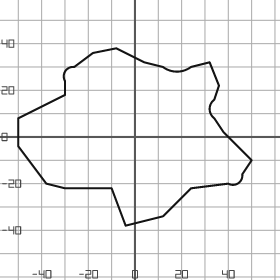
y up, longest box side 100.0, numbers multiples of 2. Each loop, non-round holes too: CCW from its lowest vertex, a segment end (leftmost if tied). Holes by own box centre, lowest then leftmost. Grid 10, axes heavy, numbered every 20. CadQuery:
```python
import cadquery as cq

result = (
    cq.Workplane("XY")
    .moveTo(-4.0, -38.0)
    .lineTo(12.0, -34.0)
    .lineTo(24.0, -22.0)
    .lineTo(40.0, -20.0)
    .threePointArc((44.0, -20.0), (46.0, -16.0))
    .lineTo(50.0, -10.0)
    .lineTo(38.0, 2.0)
    .lineTo(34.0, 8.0)
    .threePointArc((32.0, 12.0), (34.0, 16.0))
    .lineTo(36.0, 22.0)
    .lineTo(32.0, 32.0)
    .lineTo(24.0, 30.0)
    .threePointArc((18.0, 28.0), (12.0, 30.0))
    .lineTo(4.0, 32.0)
    .lineTo(-8.0, 38.0)
    .lineTo(-18.0, 36.0)
    .lineTo(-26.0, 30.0)
    .threePointArc((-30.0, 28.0), (-30.0, 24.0))
    .lineTo(-30.0, 18.0)
    .lineTo(-50.0, 8.0)
    .lineTo(-50.0, -4.0)
    .lineTo(-38.0, -20.0)
    .lineTo(-30.0, -22.0)
    .lineTo(-10.0, -22.0)
    .close()
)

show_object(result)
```